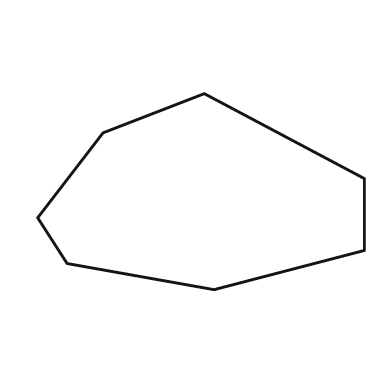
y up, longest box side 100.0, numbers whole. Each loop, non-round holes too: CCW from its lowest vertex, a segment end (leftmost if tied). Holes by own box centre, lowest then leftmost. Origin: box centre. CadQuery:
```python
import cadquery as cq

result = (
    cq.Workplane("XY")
    .moveTo(4.0, -30.0)
    .lineTo(50.0, -18.0)
    .lineTo(50.0, 4.0)
    .lineTo(1.0, 30.0)
    .lineTo(-30.0, 18.0)
    .lineTo(-50.0, -8.0)
    .lineTo(-41.0, -22.0)
    .close()
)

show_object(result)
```